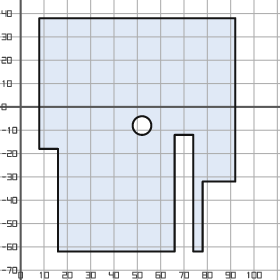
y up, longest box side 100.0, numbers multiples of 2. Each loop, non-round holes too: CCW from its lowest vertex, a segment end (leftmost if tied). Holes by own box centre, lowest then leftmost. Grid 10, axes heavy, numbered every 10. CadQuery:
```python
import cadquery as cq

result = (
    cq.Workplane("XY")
    .moveTo(16.0, -62.0)
    .lineTo(66.0, -62.0)
    .lineTo(66.0, -12.0)
    .lineTo(74.0, -12.0)
    .lineTo(74.0, -62.0)
    .lineTo(78.0, -62.0)
    .lineTo(78.0, -32.0)
    .lineTo(92.0, -32.0)
    .lineTo(92.0, 38.0)
    .lineTo(8.0, 38.0)
    .lineTo(8.0, -18.0)
    .lineTo(16.0, -18.0)
    .close()
    .moveTo(52.0, -8.0)
    .circle(4.0)
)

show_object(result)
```